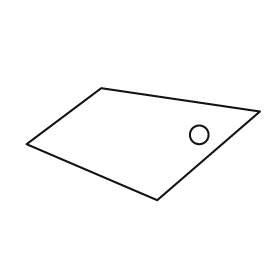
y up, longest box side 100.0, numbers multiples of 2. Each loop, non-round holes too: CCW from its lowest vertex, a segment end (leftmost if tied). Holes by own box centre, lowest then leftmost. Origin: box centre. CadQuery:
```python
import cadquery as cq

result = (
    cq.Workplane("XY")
    .moveTo(6.0, -24.0)
    .lineTo(50.0, 14.0)
    .lineTo(-18.0, 24.0)
    .lineTo(-50.0, 0.0)
    .close()
    .moveTo(24.0, 4.0)
    .circle(4.0)
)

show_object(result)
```